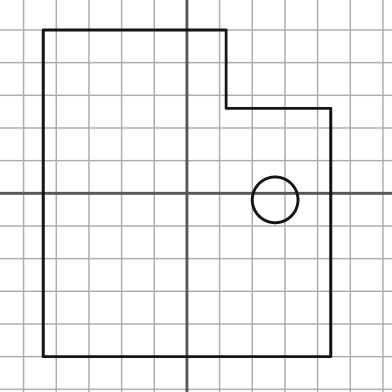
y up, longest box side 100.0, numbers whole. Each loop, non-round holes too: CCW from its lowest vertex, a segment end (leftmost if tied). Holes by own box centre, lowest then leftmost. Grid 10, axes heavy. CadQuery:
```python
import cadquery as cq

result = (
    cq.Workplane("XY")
    .moveTo(-44.0, -50.0)
    .lineTo(44.0, -50.0)
    .lineTo(44.0, 26.0)
    .lineTo(12.0, 26.0)
    .lineTo(12.0, 50.0)
    .lineTo(-44.0, 50.0)
    .close()
    .moveTo(27.0, -2.0)
    .circle(7.0)
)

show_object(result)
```